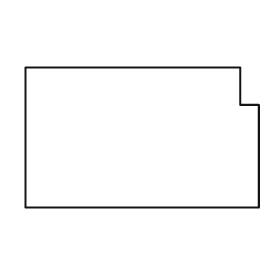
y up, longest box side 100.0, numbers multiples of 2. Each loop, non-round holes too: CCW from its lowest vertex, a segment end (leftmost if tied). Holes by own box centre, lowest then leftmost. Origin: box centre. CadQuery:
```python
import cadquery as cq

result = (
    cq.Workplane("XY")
    .moveTo(-50.0, -30.0)
    .lineTo(50.0, -30.0)
    .lineTo(50.0, 14.0)
    .lineTo(42.0, 14.0)
    .lineTo(42.0, 30.0)
    .lineTo(-50.0, 30.0)
    .close()
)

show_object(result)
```